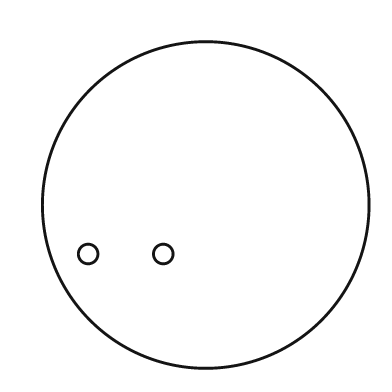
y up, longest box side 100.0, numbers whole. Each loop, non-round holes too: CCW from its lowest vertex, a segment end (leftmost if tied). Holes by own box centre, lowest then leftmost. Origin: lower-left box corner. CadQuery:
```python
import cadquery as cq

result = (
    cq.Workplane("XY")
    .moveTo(50.0, 50.0)
    .circle(50.0)
    .moveTo(14.0, 35.0)
    .circle(3.0)
    .moveTo(37.0, 35.0)
    .circle(3.0)
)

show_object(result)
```